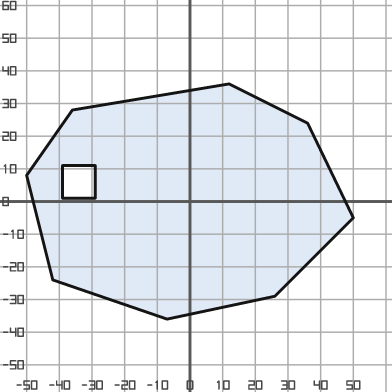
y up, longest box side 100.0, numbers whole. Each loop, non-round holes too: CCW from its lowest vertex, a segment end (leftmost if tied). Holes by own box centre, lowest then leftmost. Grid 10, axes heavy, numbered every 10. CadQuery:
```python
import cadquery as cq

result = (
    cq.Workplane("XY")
    .moveTo(-7.0, -36.0)
    .lineTo(26.0, -29.0)
    .lineTo(50.0, -5.0)
    .lineTo(36.0, 24.0)
    .lineTo(12.0, 36.0)
    .lineTo(-36.0, 28.0)
    .lineTo(-50.0, 8.0)
    .lineTo(-42.0, -24.0)
    .close()
    .moveTo(-39.0, 1.0)
    .lineTo(-29.0, 1.0)
    .lineTo(-29.0, 11.0)
    .lineTo(-39.0, 11.0)
    .close()
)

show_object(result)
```